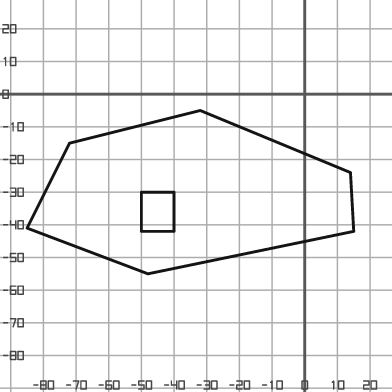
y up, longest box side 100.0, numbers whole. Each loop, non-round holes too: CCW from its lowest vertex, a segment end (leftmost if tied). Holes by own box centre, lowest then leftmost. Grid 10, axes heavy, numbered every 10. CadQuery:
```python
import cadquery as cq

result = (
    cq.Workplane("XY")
    .moveTo(-48.0, -55.0)
    .lineTo(15.0, -42.0)
    .lineTo(14.0, -24.0)
    .lineTo(-32.0, -5.0)
    .lineTo(-72.0, -15.0)
    .lineTo(-85.0, -41.0)
    .close()
    .moveTo(-50.0, -42.0)
    .lineTo(-40.0, -42.0)
    .lineTo(-40.0, -30.0)
    .lineTo(-50.0, -30.0)
    .close()
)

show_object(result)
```